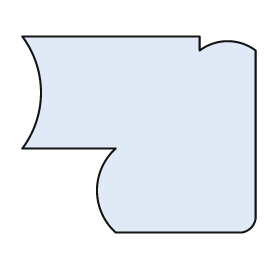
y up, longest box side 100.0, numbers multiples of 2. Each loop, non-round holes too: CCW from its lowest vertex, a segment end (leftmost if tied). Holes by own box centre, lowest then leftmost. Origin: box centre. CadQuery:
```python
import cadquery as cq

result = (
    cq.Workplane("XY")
    .moveTo(-10.0, -42.0)
    .lineTo(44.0, -42.0)
    .threePointArc((48.0, -40.0), (50.0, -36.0))
    .lineTo(50.0, 36.0)
    .threePointArc((38.0, 40.0), (26.0, 36.0))
    .lineTo(26.0, 42.0)
    .lineTo(-50.0, 42.0)
    .threePointArc((-42.0, 18.0), (-50.0, -6.0))
    .lineTo(-10.0, -6.0)
    .threePointArc((-18.0, -24.0), (-10.0, -42.0))
    .close()
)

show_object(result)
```